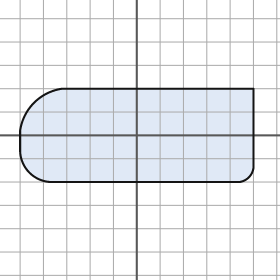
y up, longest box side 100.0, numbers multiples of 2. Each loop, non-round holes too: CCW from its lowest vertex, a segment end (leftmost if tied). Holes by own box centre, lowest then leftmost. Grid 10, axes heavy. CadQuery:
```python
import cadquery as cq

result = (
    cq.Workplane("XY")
    .moveTo(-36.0, -20.0)
    .lineTo(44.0, -20.0)
    .threePointArc((48.0, -18.0), (50.0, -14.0))
    .lineTo(50.0, 20.0)
    .lineTo(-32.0, 20.0)
    .threePointArc((-44.0, 14.0), (-50.0, 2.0))
    .lineTo(-50.0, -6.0)
    .threePointArc((-46.0, -16.0), (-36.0, -20.0))
    .close()
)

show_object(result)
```